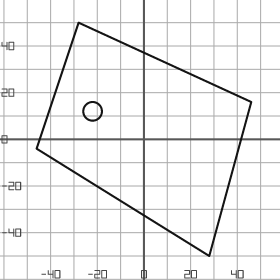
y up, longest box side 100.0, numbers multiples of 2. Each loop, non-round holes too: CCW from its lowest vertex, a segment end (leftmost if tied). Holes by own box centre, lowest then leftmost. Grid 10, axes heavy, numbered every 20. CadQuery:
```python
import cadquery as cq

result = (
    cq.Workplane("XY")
    .moveTo(28.0, -50.0)
    .lineTo(46.0, 16.0)
    .lineTo(-28.0, 50.0)
    .lineTo(-46.0, -4.0)
    .close()
    .moveTo(-22.0, 12.0)
    .circle(4.0)
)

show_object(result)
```